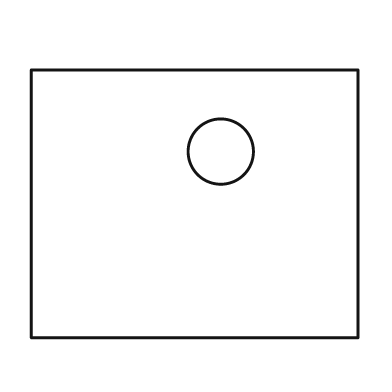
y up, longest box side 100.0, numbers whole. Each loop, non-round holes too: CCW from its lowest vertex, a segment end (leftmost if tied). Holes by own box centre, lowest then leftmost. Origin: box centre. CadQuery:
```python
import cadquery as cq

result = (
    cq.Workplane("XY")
    .moveTo(-50.0, -41.0)
    .lineTo(50.0, -41.0)
    .lineTo(50.0, 41.0)
    .lineTo(-50.0, 41.0)
    .close()
    .moveTo(8.0, 16.0)
    .circle(10.0)
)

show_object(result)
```